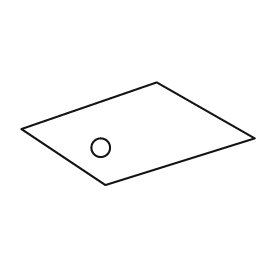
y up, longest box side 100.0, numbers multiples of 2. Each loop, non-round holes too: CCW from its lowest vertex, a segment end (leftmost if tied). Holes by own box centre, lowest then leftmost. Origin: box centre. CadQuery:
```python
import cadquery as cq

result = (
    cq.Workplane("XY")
    .moveTo(-14.0, -22.0)
    .lineTo(50.0, -2.0)
    .lineTo(8.0, 22.0)
    .lineTo(-50.0, 2.0)
    .close()
    .moveTo(-16.0, -6.0)
    .circle(4.0)
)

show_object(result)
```